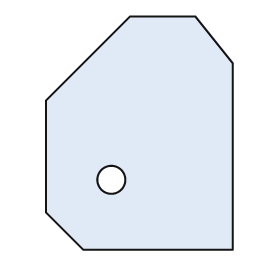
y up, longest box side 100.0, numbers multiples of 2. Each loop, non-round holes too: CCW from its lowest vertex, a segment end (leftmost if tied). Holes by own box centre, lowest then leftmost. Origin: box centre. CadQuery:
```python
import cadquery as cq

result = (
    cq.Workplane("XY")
    .moveTo(-24.0, -50.0)
    .lineTo(40.0, -50.0)
    .lineTo(40.0, 30.0)
    .lineTo(24.0, 50.0)
    .lineTo(-4.0, 50.0)
    .lineTo(-40.0, 14.0)
    .lineTo(-40.0, -34.0)
    .close()
    .moveTo(-12.0, -20.0)
    .circle(6.0)
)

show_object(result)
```